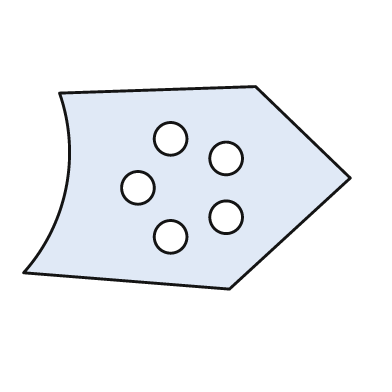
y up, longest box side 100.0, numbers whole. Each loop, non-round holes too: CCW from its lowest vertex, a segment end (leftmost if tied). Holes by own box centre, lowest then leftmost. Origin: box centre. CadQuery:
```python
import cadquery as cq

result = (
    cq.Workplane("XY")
    .moveTo(13.0, -31.0)
    .lineTo(50.0, 3.0)
    .lineTo(21.0, 31.0)
    .lineTo(-39.0, 29.0)
    .threePointArc((-37.0, 0.0), (-50.0, -26.0))
    .close()
    .moveTo(-5.0, -15.0)
    .circle(5.0)
    .moveTo(12.0, -9.0)
    .circle(5.0)
    .moveTo(-15.0, 0.0)
    .circle(5.0)
    .moveTo(12.0, 9.0)
    .circle(5.0)
    .moveTo(-5.0, 15.0)
    .circle(5.0)
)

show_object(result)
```